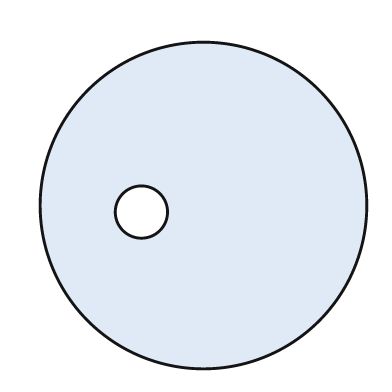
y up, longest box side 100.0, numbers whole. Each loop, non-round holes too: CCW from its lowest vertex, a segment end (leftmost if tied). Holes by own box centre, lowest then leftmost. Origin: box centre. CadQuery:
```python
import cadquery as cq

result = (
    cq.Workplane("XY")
    .moveTo(0.0, 0.0)
    .circle(50.0)
    .moveTo(-19.0, -2.0)
    .circle(8.0)
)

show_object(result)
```